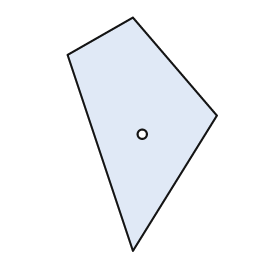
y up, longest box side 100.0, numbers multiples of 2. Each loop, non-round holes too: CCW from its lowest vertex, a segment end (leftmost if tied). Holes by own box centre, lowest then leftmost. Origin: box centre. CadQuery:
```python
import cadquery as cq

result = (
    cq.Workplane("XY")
    .moveTo(-4.0, -50.0)
    .lineTo(32.0, 8.0)
    .lineTo(-4.0, 50.0)
    .lineTo(-32.0, 34.0)
    .close()
    .moveTo(0.0, 0.0)
    .circle(2.0)
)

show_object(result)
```